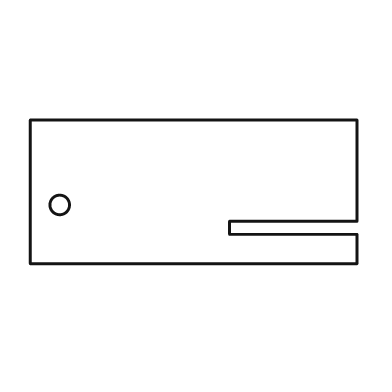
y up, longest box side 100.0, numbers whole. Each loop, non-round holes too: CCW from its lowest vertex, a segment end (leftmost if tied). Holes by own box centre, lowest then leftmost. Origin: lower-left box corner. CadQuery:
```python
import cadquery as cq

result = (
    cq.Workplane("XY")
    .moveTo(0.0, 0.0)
    .lineTo(100.0, 0.0)
    .lineTo(100.0, 9.0)
    .lineTo(61.0, 9.0)
    .lineTo(61.0, 13.0)
    .lineTo(100.0, 13.0)
    .lineTo(100.0, 44.0)
    .lineTo(0.0, 44.0)
    .close()
    .moveTo(9.0, 18.0)
    .circle(3.0)
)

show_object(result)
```